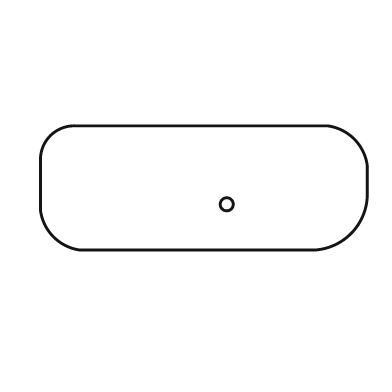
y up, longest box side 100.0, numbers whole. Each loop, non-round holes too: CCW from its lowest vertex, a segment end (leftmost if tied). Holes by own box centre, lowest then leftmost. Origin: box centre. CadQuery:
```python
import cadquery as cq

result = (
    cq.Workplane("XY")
    .moveTo(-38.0, -19.0)
    .lineTo(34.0, -19.0)
    .threePointArc((45.0, -14.0), (50.0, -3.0))
    .lineTo(50.0, 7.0)
    .threePointArc((46.0, 15.0), (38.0, 19.0))
    .lineTo(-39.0, 19.0)
    .threePointArc((-47.0, 16.0), (-50.0, 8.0))
    .lineTo(-50.0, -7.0)
    .threePointArc((-46.0, -15.0), (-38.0, -19.0))
    .close()
    .moveTo(7.0, -5.0)
    .circle(2.0)
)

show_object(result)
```